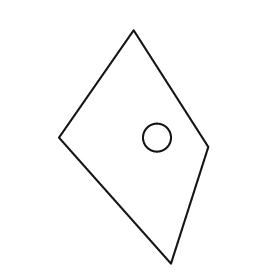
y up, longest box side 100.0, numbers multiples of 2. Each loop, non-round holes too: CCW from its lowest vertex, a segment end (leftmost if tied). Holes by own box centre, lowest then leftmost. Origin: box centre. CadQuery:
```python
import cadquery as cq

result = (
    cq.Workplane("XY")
    .moveTo(16.0, -50.0)
    .lineTo(32.0, 0.0)
    .lineTo(0.0, 50.0)
    .lineTo(-32.0, 4.0)
    .close()
    .moveTo(10.0, 4.0)
    .circle(6.0)
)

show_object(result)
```